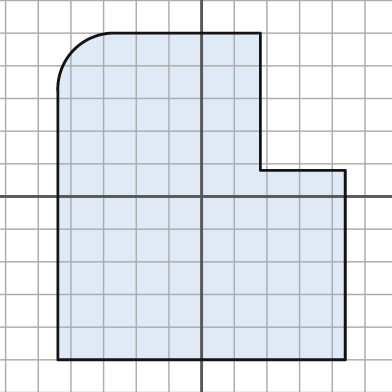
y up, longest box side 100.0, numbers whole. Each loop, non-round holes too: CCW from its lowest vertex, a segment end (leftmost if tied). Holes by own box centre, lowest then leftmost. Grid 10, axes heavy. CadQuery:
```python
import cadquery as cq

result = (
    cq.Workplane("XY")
    .moveTo(-44.0, -50.0)
    .lineTo(44.0, -50.0)
    .lineTo(44.0, 8.0)
    .lineTo(18.0, 8.0)
    .lineTo(18.0, 50.0)
    .lineTo(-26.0, 50.0)
    .threePointArc((-39.0, 45.0), (-44.0, 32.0))
    .close()
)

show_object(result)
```